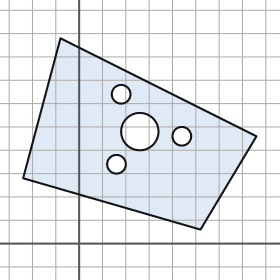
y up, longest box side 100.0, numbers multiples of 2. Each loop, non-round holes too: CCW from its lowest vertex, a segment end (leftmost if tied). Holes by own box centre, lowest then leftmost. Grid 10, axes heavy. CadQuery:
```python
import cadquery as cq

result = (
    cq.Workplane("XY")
    .moveTo(52.0, 6.0)
    .lineTo(76.0, 46.0)
    .lineTo(-8.0, 88.0)
    .lineTo(-24.0, 28.0)
    .close()
    .moveTo(16.0, 34.0)
    .circle(4.0)
    .moveTo(44.0, 46.0)
    .circle(4.0)
    .moveTo(26.0, 48.0)
    .circle(8.0)
    .moveTo(18.0, 64.0)
    .circle(4.0)
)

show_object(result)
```